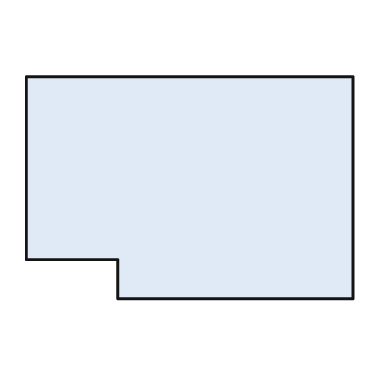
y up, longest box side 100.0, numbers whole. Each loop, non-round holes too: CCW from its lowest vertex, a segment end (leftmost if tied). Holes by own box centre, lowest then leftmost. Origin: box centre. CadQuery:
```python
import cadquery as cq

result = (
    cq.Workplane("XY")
    .moveTo(-22.0, -34.0)
    .lineTo(50.0, -34.0)
    .lineTo(50.0, 34.0)
    .lineTo(-50.0, 34.0)
    .lineTo(-50.0, -22.0)
    .lineTo(-22.0, -22.0)
    .close()
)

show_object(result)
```